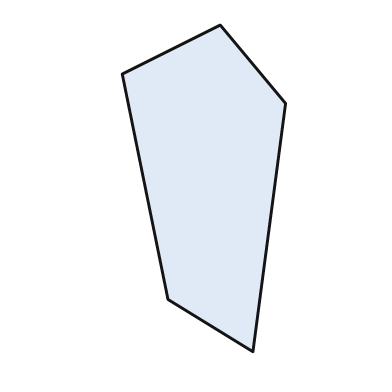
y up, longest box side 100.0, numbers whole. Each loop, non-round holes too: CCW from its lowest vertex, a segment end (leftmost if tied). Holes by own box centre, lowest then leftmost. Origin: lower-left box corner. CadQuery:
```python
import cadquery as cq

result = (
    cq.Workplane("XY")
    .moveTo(40.0, 0.0)
    .lineTo(50.0, 76.0)
    .lineTo(30.0, 100.0)
    .lineTo(0.0, 85.0)
    .lineTo(14.0, 16.0)
    .close()
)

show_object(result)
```